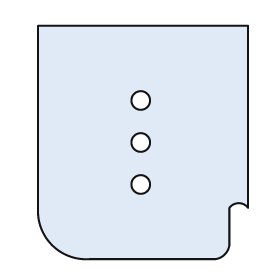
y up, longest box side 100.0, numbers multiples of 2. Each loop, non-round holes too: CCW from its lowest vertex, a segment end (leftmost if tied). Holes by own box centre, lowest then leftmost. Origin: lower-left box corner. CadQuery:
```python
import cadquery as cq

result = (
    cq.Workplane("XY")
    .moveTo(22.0, 0.0)
    .lineTo(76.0, 0.0)
    .threePointArc((80.0, 2.0), (82.0, 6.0))
    .lineTo(82.0, 22.0)
    .threePointArc((86.0, 24.0), (90.0, 22.0))
    .lineTo(90.0, 100.0)
    .lineTo(0.0, 100.0)
    .lineTo(0.0, 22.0)
    .threePointArc((6.0, 6.0), (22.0, 0.0))
    .close()
    .moveTo(44.0, 32.0)
    .circle(4.0)
    .moveTo(44.0, 50.0)
    .circle(4.0)
    .moveTo(44.0, 68.0)
    .circle(4.0)
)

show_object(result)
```